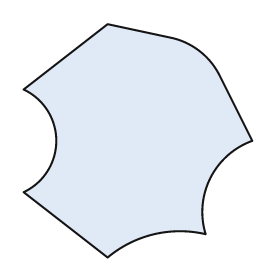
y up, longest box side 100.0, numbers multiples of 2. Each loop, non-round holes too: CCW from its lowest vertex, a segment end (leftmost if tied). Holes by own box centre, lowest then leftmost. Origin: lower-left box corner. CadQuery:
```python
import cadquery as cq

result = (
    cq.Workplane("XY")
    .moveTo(36.0, 0.0)
    .threePointArc((56.0, 10.0), (78.0, 10.0))
    .threePointArc((80.0, 34.0), (98.0, 50.0))
    .lineTo(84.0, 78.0)
    .threePointArc((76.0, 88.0), (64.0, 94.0))
    .lineTo(36.0, 100.0)
    .lineTo(0.0, 72.0)
    .threePointArc((14.0, 50.0), (0.0, 28.0))
    .close()
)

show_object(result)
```